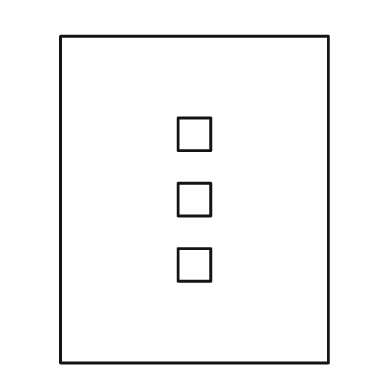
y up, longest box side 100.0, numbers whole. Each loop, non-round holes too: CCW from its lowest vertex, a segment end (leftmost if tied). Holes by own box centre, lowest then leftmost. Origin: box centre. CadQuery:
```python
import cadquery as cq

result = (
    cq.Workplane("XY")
    .moveTo(-41.0, -50.0)
    .lineTo(41.0, -50.0)
    .lineTo(41.0, 50.0)
    .lineTo(-41.0, 50.0)
    .close()
    .moveTo(-5.0, -25.0)
    .lineTo(5.0, -25.0)
    .lineTo(5.0, -15.0)
    .lineTo(-5.0, -15.0)
    .close()
    .moveTo(-5.0, -5.0)
    .lineTo(5.0, -5.0)
    .lineTo(5.0, 5.0)
    .lineTo(-5.0, 5.0)
    .close()
    .moveTo(-5.0, 15.0)
    .lineTo(5.0, 15.0)
    .lineTo(5.0, 25.0)
    .lineTo(-5.0, 25.0)
    .close()
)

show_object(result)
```